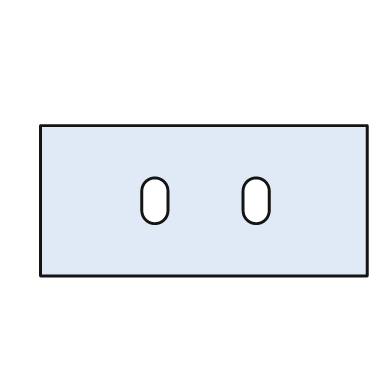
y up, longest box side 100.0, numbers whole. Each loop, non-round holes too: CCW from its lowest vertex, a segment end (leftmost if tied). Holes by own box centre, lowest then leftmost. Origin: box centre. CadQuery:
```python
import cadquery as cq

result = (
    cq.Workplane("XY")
    .moveTo(-50.0, -23.0)
    .lineTo(50.0, -23.0)
    .lineTo(50.0, 23.0)
    .lineTo(-50.0, 23.0)
    .close()
    .moveTo(-19.0, -3.0)
    .threePointArc((-15.0, -7.0), (-11.0, -3.0))
    .lineTo(-11.0, 3.0)
    .threePointArc((-15.0, 7.0), (-19.0, 3.0))
    .close()
    .moveTo(12.0, -3.0)
    .threePointArc((16.0, -7.0), (20.0, -3.0))
    .lineTo(20.0, 3.0)
    .threePointArc((16.0, 7.0), (12.0, 3.0))
    .close()
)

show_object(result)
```